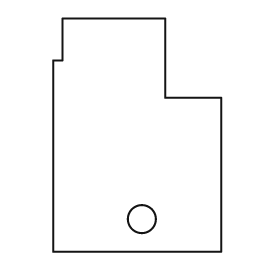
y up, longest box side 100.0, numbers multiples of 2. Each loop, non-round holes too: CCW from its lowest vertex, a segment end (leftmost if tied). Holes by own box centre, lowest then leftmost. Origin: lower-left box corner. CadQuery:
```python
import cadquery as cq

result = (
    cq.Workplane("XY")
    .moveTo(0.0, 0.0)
    .lineTo(72.0, 0.0)
    .lineTo(72.0, 66.0)
    .lineTo(48.0, 66.0)
    .lineTo(48.0, 100.0)
    .lineTo(4.0, 100.0)
    .lineTo(4.0, 82.0)
    .lineTo(0.0, 82.0)
    .close()
    .moveTo(38.0, 14.0)
    .circle(6.0)
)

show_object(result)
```